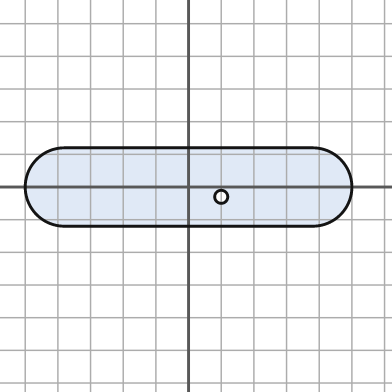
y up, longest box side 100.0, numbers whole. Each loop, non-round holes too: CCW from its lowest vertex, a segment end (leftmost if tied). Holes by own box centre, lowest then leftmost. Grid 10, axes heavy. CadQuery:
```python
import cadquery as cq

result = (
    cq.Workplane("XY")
    .moveTo(-38.0, -12.0)
    .lineTo(38.0, -12.0)
    .threePointArc((50.0, 0.0), (38.0, 12.0))
    .lineTo(-38.0, 12.0)
    .threePointArc((-50.0, 0.0), (-38.0, -12.0))
    .close()
    .moveTo(10.0, -3.0)
    .circle(2.0)
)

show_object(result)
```